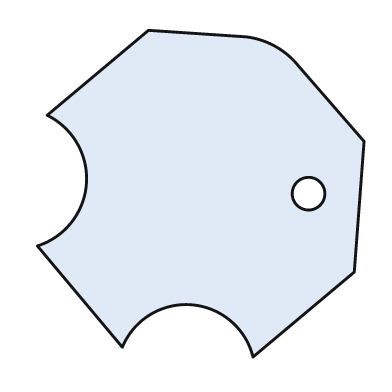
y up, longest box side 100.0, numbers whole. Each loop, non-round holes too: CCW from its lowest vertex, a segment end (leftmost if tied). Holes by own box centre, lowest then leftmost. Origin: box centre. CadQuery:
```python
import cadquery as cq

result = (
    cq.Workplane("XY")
    .moveTo(16.0, -50.0)
    .lineTo(47.0, -24.0)
    .lineTo(50.0, 16.0)
    .lineTo(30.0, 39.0)
    .threePointArc((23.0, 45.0), (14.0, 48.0))
    .lineTo(-16.0, 50.0)
    .lineTo(-47.0, 24.0)
    .threePointArc((-35.0, 3.0), (-50.0, -16.0))
    .lineTo(-24.0, -47.0)
    .threePointArc((-3.0, -34.0), (16.0, -50.0))
    .close()
    .moveTo(33.0, 0.0)
    .circle(5.0)
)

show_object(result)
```